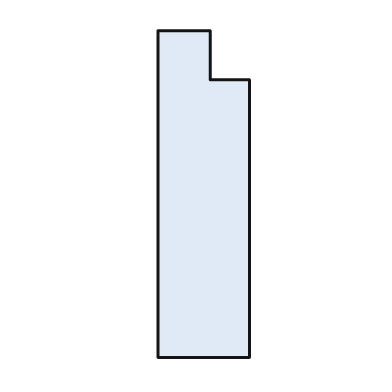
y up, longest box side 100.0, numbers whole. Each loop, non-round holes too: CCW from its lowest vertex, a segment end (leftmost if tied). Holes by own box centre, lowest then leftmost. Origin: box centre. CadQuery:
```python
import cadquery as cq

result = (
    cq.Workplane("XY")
    .moveTo(-14.0, -50.0)
    .lineTo(14.0, -50.0)
    .lineTo(14.0, 35.0)
    .lineTo(2.0, 35.0)
    .lineTo(2.0, 50.0)
    .lineTo(-14.0, 50.0)
    .close()
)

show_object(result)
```